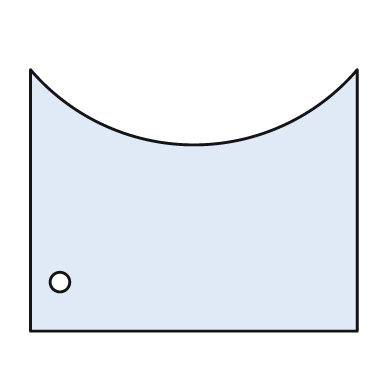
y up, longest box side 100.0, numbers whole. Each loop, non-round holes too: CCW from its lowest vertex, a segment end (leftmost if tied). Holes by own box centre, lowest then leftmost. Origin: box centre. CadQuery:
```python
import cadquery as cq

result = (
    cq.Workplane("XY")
    .moveTo(-50.0, -40.0)
    .lineTo(50.0, -40.0)
    .lineTo(50.0, 40.0)
    .threePointArc((0.0, 17.0), (-50.0, 40.0))
    .close()
    .moveTo(-41.0, -25.0)
    .circle(3.0)
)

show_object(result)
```